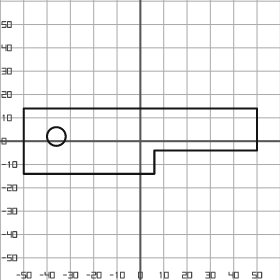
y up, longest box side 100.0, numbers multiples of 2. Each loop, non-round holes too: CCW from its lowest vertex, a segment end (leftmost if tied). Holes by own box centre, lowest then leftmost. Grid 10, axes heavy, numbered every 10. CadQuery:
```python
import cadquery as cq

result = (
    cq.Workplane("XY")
    .moveTo(-50.0, -14.0)
    .lineTo(6.0, -14.0)
    .lineTo(6.0, -4.0)
    .lineTo(50.0, -4.0)
    .lineTo(50.0, 14.0)
    .lineTo(-50.0, 14.0)
    .close()
    .moveTo(-36.0, 2.0)
    .circle(4.0)
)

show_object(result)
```